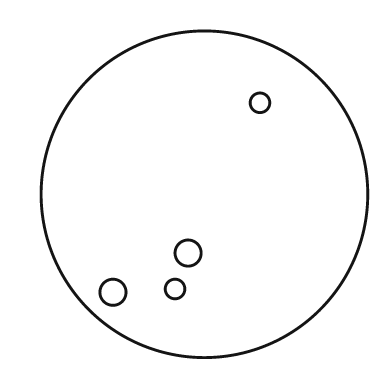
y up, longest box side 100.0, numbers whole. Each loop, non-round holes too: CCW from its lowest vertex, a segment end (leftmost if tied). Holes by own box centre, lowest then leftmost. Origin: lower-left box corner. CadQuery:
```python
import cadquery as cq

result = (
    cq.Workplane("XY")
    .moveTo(50.0, 50.0)
    .circle(50.0)
    .moveTo(22.0, 20.0)
    .circle(4.0)
    .moveTo(41.0, 21.0)
    .circle(3.0)
    .moveTo(45.0, 32.0)
    .circle(4.0)
    .moveTo(67.0, 78.0)
    .circle(3.0)
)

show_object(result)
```